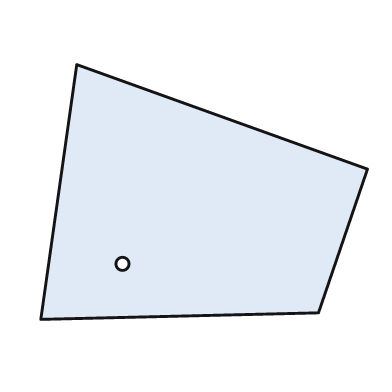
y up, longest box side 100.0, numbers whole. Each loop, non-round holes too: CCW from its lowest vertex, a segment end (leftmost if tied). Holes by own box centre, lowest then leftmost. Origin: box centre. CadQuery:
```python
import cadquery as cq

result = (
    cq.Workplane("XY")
    .moveTo(-50.0, -39.0)
    .lineTo(35.0, -37.0)
    .lineTo(50.0, 7.0)
    .lineTo(-39.0, 39.0)
    .close()
    .moveTo(-25.0, -22.0)
    .circle(2.0)
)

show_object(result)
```